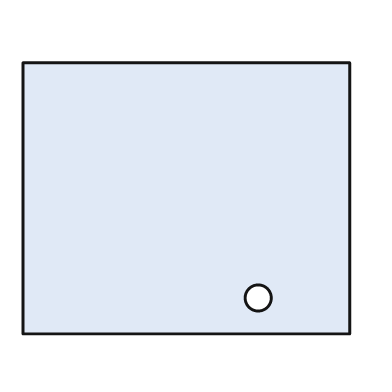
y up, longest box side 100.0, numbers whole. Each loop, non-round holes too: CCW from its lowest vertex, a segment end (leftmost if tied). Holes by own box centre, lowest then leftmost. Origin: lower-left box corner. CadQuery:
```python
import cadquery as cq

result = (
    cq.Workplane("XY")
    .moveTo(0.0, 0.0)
    .lineTo(100.0, 0.0)
    .lineTo(100.0, 83.0)
    .lineTo(0.0, 83.0)
    .close()
    .moveTo(72.0, 11.0)
    .circle(4.0)
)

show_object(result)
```